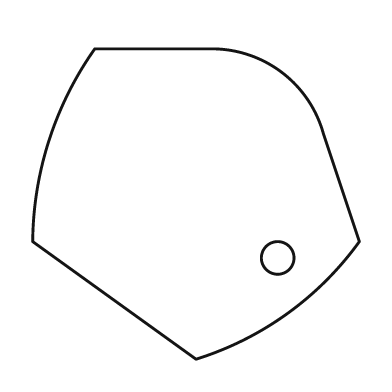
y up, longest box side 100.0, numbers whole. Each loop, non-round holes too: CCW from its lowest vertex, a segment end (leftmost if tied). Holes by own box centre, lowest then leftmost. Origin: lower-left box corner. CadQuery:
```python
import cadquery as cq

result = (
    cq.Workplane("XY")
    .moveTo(50.0, 0.0)
    .threePointArc((78.0, 14.0), (100.0, 36.0))
    .lineTo(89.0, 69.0)
    .threePointArc((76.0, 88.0), (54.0, 95.0))
    .lineTo(19.0, 95.0)
    .threePointArc((5.0, 67.0), (0.0, 36.0))
    .close()
    .moveTo(75.0, 31.0)
    .circle(5.0)
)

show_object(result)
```